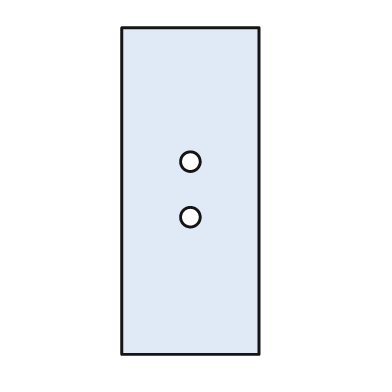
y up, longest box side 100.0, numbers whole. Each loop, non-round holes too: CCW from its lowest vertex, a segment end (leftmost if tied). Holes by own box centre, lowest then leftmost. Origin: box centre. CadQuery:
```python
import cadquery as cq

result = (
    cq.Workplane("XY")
    .moveTo(-21.0, -50.0)
    .lineTo(21.0, -50.0)
    .lineTo(21.0, 50.0)
    .lineTo(-21.0, 50.0)
    .close()
    .moveTo(0.0, -8.0)
    .circle(3.0)
    .moveTo(0.0, 9.0)
    .circle(3.0)
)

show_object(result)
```